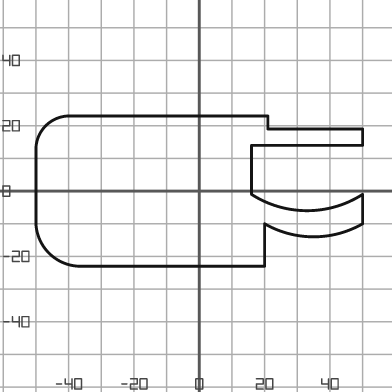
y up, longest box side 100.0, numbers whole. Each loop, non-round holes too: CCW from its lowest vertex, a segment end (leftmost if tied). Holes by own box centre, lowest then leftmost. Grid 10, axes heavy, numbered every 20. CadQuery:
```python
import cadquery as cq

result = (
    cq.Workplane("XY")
    .moveTo(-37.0, -23.0)
    .lineTo(20.0, -23.0)
    .lineTo(20.0, -10.0)
    .threePointArc((35.0, -14.0), (50.0, -10.0))
    .lineTo(50.0, -1.0)
    .threePointArc((33.0, -6.0), (16.0, -1.0))
    .lineTo(16.0, 14.0)
    .lineTo(50.0, 14.0)
    .lineTo(50.0, 19.0)
    .lineTo(21.0, 19.0)
    .lineTo(21.0, 23.0)
    .lineTo(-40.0, 23.0)
    .threePointArc((-47.0, 20.0), (-50.0, 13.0))
    .lineTo(-50.0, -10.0)
    .threePointArc((-46.0, -19.0), (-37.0, -23.0))
    .close()
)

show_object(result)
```